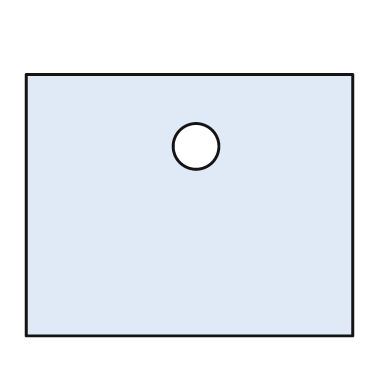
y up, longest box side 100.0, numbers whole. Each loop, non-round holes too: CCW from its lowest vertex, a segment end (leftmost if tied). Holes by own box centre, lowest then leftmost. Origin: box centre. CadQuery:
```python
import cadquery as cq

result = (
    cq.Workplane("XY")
    .moveTo(-50.0, -40.0)
    .lineTo(50.0, -40.0)
    .lineTo(50.0, 40.0)
    .lineTo(-50.0, 40.0)
    .close()
    .moveTo(2.0, 18.0)
    .circle(7.0)
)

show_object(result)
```